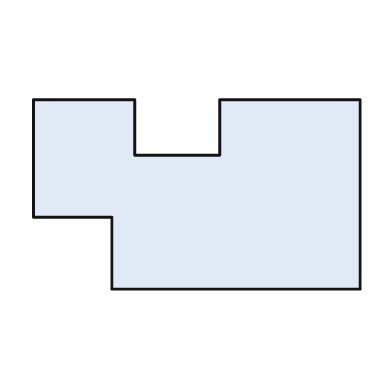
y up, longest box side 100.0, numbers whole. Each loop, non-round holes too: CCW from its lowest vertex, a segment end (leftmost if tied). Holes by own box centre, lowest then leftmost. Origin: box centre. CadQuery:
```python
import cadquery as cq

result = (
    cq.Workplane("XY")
    .moveTo(-26.0, -29.0)
    .lineTo(50.0, -29.0)
    .lineTo(50.0, 29.0)
    .lineTo(7.0, 29.0)
    .lineTo(7.0, 12.0)
    .lineTo(-19.0, 12.0)
    .lineTo(-19.0, 29.0)
    .lineTo(-50.0, 29.0)
    .lineTo(-50.0, -7.0)
    .lineTo(-26.0, -7.0)
    .close()
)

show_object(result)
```